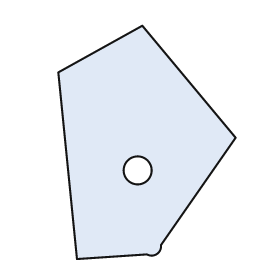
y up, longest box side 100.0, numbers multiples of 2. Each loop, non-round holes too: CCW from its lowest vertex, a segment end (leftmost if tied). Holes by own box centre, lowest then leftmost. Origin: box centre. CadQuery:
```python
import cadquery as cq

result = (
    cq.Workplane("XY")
    .moveTo(-30.0, -50.0)
    .lineTo(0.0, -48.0)
    .threePointArc((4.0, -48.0), (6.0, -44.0))
    .lineTo(38.0, 2.0)
    .lineTo(-2.0, 50.0)
    .lineTo(-38.0, 30.0)
    .close()
    .moveTo(-4.0, -12.0)
    .circle(6.0)
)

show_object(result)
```